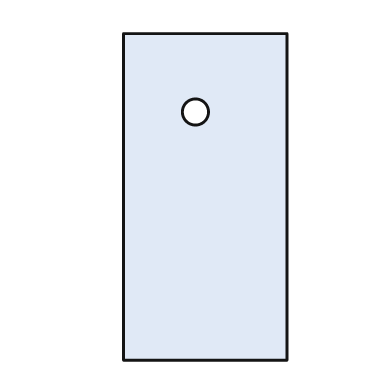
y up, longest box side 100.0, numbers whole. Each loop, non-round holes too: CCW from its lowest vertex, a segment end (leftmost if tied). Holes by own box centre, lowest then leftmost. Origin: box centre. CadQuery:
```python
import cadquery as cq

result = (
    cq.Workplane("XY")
    .moveTo(-25.0, -50.0)
    .lineTo(25.0, -50.0)
    .lineTo(25.0, 50.0)
    .lineTo(-25.0, 50.0)
    .close()
    .moveTo(-3.0, 26.0)
    .circle(4.0)
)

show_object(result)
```